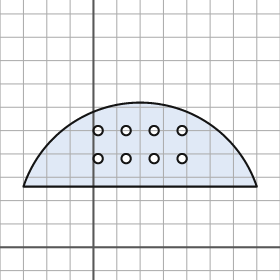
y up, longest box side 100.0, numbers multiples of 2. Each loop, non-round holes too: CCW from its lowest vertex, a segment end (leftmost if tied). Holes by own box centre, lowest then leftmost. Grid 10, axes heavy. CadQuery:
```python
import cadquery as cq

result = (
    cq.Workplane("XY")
    .moveTo(-30.0, 26.0)
    .lineTo(70.0, 26.0)
    .threePointArc((20.0, 62.0), (-30.0, 26.0))
    .close()
    .moveTo(2.0, 38.0)
    .circle(2.0)
    .moveTo(14.0, 38.0)
    .circle(2.0)
    .moveTo(26.0, 38.0)
    .circle(2.0)
    .moveTo(38.0, 38.0)
    .circle(2.0)
    .moveTo(2.0, 50.0)
    .circle(2.0)
    .moveTo(14.0, 50.0)
    .circle(2.0)
    .moveTo(26.0, 50.0)
    .circle(2.0)
    .moveTo(38.0, 50.0)
    .circle(2.0)
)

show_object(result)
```